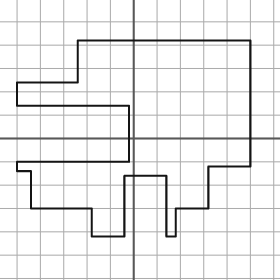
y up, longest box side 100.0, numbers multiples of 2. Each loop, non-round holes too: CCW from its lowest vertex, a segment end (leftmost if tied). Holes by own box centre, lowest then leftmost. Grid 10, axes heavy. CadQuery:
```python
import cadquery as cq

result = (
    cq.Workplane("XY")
    .moveTo(-18.0, -42.0)
    .lineTo(-4.0, -42.0)
    .lineTo(-4.0, -16.0)
    .lineTo(14.0, -16.0)
    .lineTo(14.0, -42.0)
    .lineTo(18.0, -42.0)
    .lineTo(18.0, -30.0)
    .lineTo(32.0, -30.0)
    .lineTo(32.0, -12.0)
    .lineTo(50.0, -12.0)
    .lineTo(50.0, 42.0)
    .lineTo(-24.0, 42.0)
    .lineTo(-24.0, 24.0)
    .lineTo(-50.0, 24.0)
    .lineTo(-50.0, 14.0)
    .lineTo(-2.0, 14.0)
    .lineTo(-2.0, -10.0)
    .lineTo(-50.0, -10.0)
    .lineTo(-50.0, -14.0)
    .lineTo(-44.0, -14.0)
    .lineTo(-44.0, -30.0)
    .lineTo(-18.0, -30.0)
    .close()
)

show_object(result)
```